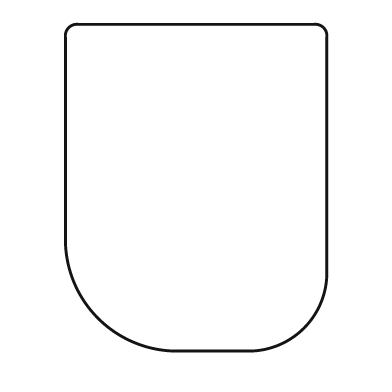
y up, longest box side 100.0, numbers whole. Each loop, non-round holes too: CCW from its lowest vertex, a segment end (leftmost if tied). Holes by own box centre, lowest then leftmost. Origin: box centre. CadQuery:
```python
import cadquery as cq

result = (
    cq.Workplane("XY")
    .moveTo(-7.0, -50.0)
    .lineTo(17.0, -50.0)
    .threePointArc((33.0, -43.0), (40.0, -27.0))
    .lineTo(40.0, 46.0)
    .threePointArc((39.0, 49.0), (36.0, 50.0))
    .lineTo(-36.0, 50.0)
    .threePointArc((-39.0, 49.0), (-40.0, 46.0))
    .lineTo(-40.0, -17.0)
    .threePointArc((-30.0, -40.0), (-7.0, -50.0))
    .close()
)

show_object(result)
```